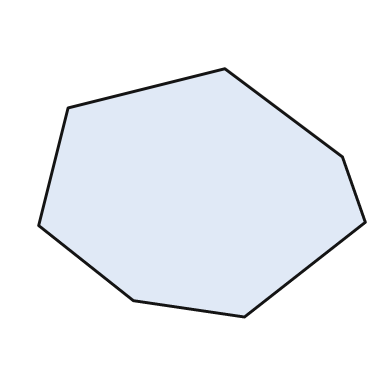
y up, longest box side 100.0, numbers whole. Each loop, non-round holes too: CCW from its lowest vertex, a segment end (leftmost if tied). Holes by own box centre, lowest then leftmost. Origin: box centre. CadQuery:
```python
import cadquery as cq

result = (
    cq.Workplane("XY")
    .moveTo(13.0, -38.0)
    .lineTo(50.0, -9.0)
    .lineTo(43.0, 11.0)
    .lineTo(7.0, 38.0)
    .lineTo(-41.0, 26.0)
    .lineTo(-50.0, -10.0)
    .lineTo(-21.0, -33.0)
    .close()
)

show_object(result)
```